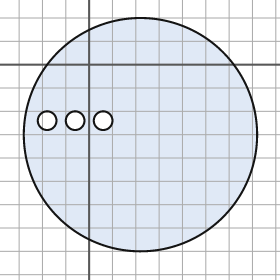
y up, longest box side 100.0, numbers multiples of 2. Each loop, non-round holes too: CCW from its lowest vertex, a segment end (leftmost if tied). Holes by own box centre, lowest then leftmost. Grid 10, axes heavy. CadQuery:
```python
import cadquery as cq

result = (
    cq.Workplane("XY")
    .moveTo(22.0, -30.0)
    .circle(50.0)
    .moveTo(-18.0, -24.0)
    .circle(4.0)
    .moveTo(-6.0, -24.0)
    .circle(4.0)
    .moveTo(6.0, -24.0)
    .circle(4.0)
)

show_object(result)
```